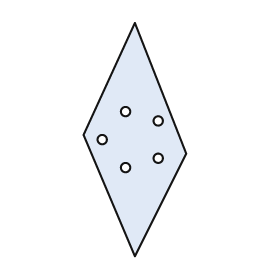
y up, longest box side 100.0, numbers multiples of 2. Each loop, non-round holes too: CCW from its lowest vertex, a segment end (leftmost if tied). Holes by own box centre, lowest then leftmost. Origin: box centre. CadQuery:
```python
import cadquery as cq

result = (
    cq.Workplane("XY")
    .moveTo(0.0, -50.0)
    .lineTo(22.0, -6.0)
    .lineTo(0.0, 50.0)
    .lineTo(-22.0, 2.0)
    .close()
    .moveTo(-4.0, -12.0)
    .circle(2.0)
    .moveTo(10.0, -8.0)
    .circle(2.0)
    .moveTo(-14.0, 0.0)
    .circle(2.0)
    .moveTo(10.0, 8.0)
    .circle(2.0)
    .moveTo(-4.0, 12.0)
    .circle(2.0)
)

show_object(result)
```